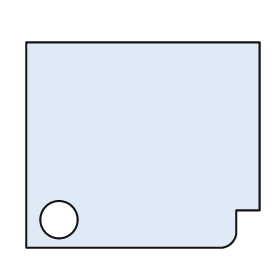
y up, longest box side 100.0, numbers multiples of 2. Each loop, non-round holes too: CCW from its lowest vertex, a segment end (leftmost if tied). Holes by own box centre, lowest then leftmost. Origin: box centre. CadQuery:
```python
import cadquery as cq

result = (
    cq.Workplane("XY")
    .moveTo(-50.0, -44.0)
    .lineTo(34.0, -44.0)
    .threePointArc((38.0, -42.0), (40.0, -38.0))
    .lineTo(40.0, -28.0)
    .lineTo(50.0, -28.0)
    .lineTo(50.0, 44.0)
    .lineTo(-50.0, 44.0)
    .close()
    .moveTo(-36.0, -32.0)
    .circle(8.0)
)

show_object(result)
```